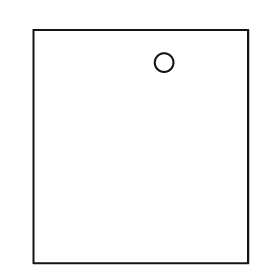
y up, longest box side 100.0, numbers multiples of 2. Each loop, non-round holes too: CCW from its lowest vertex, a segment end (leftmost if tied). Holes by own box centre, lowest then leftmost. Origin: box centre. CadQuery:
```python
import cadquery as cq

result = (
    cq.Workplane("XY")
    .moveTo(-46.0, -50.0)
    .lineTo(46.0, -50.0)
    .lineTo(46.0, 50.0)
    .lineTo(-46.0, 50.0)
    .close()
    .moveTo(10.0, 36.0)
    .circle(4.0)
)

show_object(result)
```